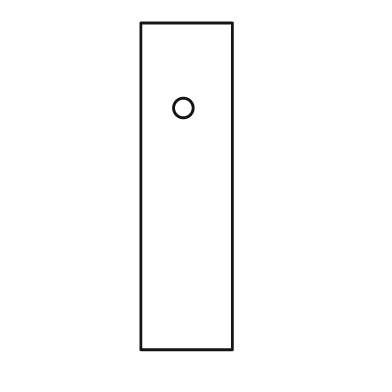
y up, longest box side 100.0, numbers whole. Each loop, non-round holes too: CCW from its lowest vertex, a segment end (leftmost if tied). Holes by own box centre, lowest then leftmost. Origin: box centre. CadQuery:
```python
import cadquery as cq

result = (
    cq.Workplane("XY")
    .moveTo(-14.0, -50.0)
    .lineTo(14.0, -50.0)
    .lineTo(14.0, 50.0)
    .lineTo(-14.0, 50.0)
    .close()
    .moveTo(-1.0, 24.0)
    .circle(3.0)
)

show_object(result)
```